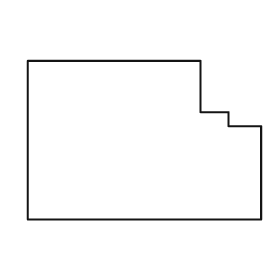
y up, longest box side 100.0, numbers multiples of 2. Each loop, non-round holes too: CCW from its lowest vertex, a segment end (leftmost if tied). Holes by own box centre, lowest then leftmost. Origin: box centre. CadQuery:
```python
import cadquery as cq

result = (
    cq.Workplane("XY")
    .moveTo(-50.0, -34.0)
    .lineTo(50.0, -34.0)
    .lineTo(50.0, 6.0)
    .lineTo(36.0, 6.0)
    .lineTo(36.0, 12.0)
    .lineTo(24.0, 12.0)
    .lineTo(24.0, 34.0)
    .lineTo(-50.0, 34.0)
    .close()
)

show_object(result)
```